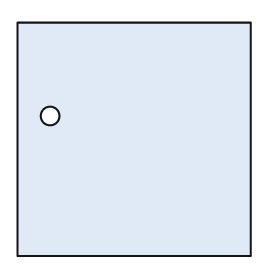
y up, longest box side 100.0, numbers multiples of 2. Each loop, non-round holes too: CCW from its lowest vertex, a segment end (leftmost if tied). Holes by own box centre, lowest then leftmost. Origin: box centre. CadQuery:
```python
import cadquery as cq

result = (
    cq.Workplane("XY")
    .moveTo(-50.0, -50.0)
    .lineTo(50.0, -50.0)
    .lineTo(50.0, 50.0)
    .lineTo(-50.0, 50.0)
    .close()
    .moveTo(-36.0, 10.0)
    .circle(4.0)
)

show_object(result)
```